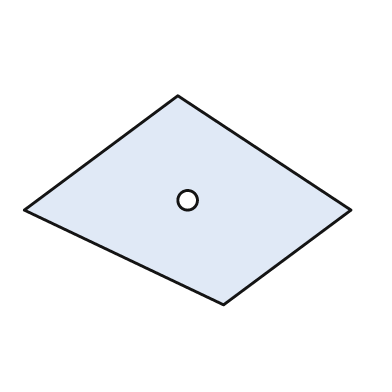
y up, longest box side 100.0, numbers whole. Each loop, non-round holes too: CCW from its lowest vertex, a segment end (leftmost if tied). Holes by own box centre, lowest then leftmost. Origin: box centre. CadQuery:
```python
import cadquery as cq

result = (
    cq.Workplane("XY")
    .moveTo(11.0, -32.0)
    .lineTo(50.0, -3.0)
    .lineTo(-3.0, 32.0)
    .lineTo(-50.0, -3.0)
    .close()
    .moveTo(0.0, 0.0)
    .circle(3.0)
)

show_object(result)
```